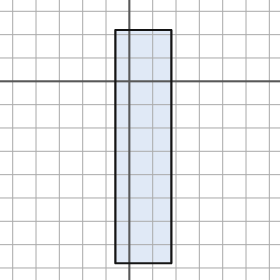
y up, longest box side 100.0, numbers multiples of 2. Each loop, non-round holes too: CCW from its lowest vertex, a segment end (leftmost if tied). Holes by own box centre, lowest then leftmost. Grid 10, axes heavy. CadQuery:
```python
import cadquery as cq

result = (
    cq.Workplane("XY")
    .moveTo(-6.0, -78.0)
    .lineTo(18.0, -78.0)
    .lineTo(18.0, 22.0)
    .lineTo(-6.0, 22.0)
    .close()
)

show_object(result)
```